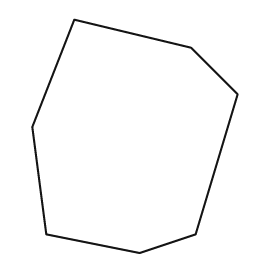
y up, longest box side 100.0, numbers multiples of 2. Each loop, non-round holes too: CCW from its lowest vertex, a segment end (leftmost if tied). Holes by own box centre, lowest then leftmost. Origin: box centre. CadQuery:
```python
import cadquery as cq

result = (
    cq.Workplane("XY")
    .moveTo(2.0, -50.0)
    .lineTo(26.0, -42.0)
    .lineTo(44.0, 18.0)
    .lineTo(24.0, 38.0)
    .lineTo(-26.0, 50.0)
    .lineTo(-44.0, 4.0)
    .lineTo(-38.0, -42.0)
    .close()
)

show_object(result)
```